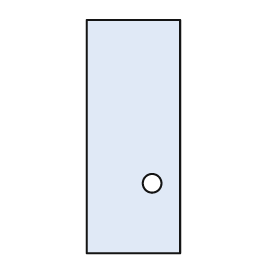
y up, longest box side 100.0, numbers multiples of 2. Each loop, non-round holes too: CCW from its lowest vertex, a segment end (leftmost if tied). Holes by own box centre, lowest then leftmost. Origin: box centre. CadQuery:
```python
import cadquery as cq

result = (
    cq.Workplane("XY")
    .moveTo(-20.0, -50.0)
    .lineTo(20.0, -50.0)
    .lineTo(20.0, 50.0)
    .lineTo(-20.0, 50.0)
    .close()
    .moveTo(8.0, -20.0)
    .circle(4.0)
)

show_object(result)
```